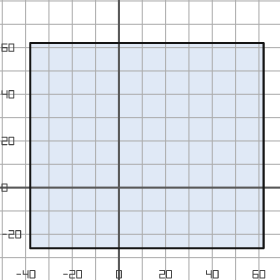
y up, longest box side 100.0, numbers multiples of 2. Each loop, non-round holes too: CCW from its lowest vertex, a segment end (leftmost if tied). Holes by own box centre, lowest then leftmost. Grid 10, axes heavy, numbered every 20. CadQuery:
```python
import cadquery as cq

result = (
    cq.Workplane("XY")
    .moveTo(-38.0, -26.0)
    .lineTo(62.0, -26.0)
    .lineTo(62.0, 62.0)
    .lineTo(-38.0, 62.0)
    .close()
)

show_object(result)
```